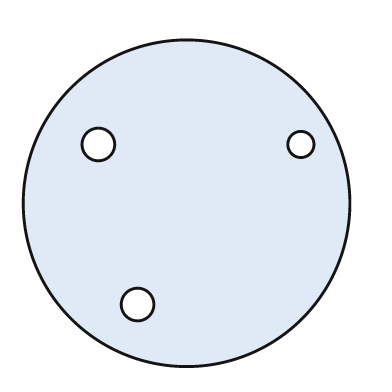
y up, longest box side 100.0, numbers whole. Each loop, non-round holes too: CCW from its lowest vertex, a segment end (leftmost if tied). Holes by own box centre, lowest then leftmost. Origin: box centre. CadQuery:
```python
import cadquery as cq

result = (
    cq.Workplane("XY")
    .moveTo(0.0, 0.0)
    .circle(50.0)
    .moveTo(-15.0, -31.0)
    .circle(5.0)
    .moveTo(-27.0, 18.0)
    .circle(5.0)
    .moveTo(35.0, 18.0)
    .circle(4.0)
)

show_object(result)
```